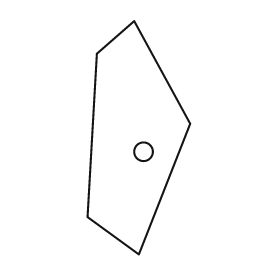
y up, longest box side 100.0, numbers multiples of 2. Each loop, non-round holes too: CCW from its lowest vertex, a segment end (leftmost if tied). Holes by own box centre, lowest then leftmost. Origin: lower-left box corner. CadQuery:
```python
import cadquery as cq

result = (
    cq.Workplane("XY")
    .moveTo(22.0, 0.0)
    .lineTo(44.0, 56.0)
    .lineTo(20.0, 100.0)
    .lineTo(4.0, 86.0)
    .lineTo(0.0, 16.0)
    .close()
    .moveTo(24.0, 44.0)
    .circle(4.0)
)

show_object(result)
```